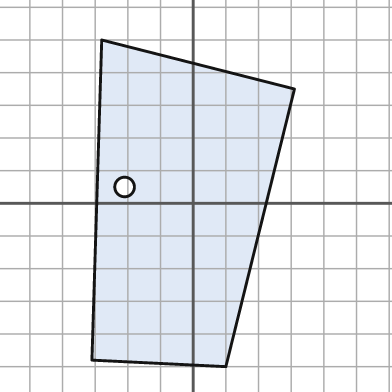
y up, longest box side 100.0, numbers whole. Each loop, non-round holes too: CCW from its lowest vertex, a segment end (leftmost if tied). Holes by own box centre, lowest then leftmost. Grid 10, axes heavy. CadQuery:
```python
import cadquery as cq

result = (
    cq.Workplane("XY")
    .moveTo(10.0, -50.0)
    .lineTo(31.0, 35.0)
    .lineTo(-28.0, 50.0)
    .lineTo(-31.0, -48.0)
    .close()
    .moveTo(-21.0, 5.0)
    .circle(3.0)
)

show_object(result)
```